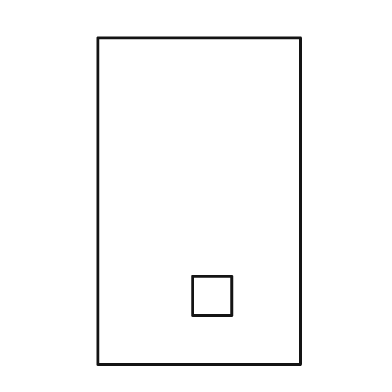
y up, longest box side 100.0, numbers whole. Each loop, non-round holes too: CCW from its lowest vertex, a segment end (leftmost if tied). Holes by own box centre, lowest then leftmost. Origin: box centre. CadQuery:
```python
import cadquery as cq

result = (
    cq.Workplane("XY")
    .moveTo(-31.0, -50.0)
    .lineTo(31.0, -50.0)
    .lineTo(31.0, 50.0)
    .lineTo(-31.0, 50.0)
    .close()
    .moveTo(-2.0, -35.0)
    .lineTo(10.0, -35.0)
    .lineTo(10.0, -23.0)
    .lineTo(-2.0, -23.0)
    .close()
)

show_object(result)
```